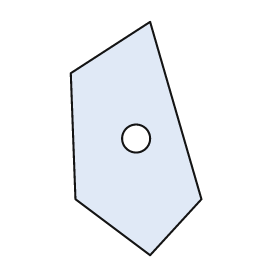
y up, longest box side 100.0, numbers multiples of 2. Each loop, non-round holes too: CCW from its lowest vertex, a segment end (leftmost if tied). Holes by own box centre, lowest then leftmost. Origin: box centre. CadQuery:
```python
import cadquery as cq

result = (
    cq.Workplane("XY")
    .moveTo(6.0, -50.0)
    .lineTo(28.0, -26.0)
    .lineTo(6.0, 50.0)
    .lineTo(-28.0, 28.0)
    .lineTo(-26.0, -26.0)
    .close()
    .moveTo(0.0, 0.0)
    .circle(6.0)
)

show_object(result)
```